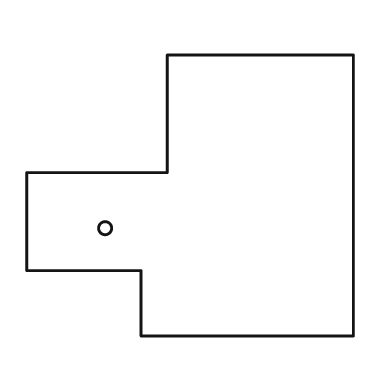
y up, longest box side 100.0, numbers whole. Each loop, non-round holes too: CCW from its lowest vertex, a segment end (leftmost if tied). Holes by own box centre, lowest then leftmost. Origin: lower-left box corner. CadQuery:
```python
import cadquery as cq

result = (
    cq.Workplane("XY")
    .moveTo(35.0, 0.0)
    .lineTo(100.0, 0.0)
    .lineTo(100.0, 86.0)
    .lineTo(43.0, 86.0)
    .lineTo(43.0, 50.0)
    .lineTo(0.0, 50.0)
    .lineTo(0.0, 20.0)
    .lineTo(35.0, 20.0)
    .close()
    .moveTo(24.0, 33.0)
    .circle(2.0)
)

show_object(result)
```